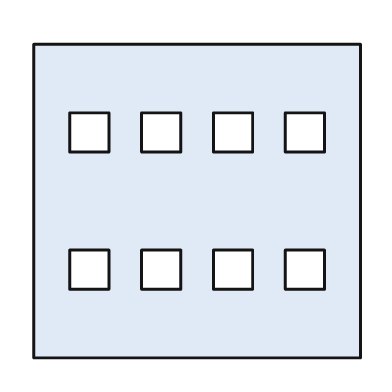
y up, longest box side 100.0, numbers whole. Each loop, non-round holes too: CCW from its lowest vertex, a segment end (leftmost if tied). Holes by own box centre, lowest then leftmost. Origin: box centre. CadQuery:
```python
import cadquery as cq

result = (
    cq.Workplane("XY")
    .moveTo(-50.0, -48.0)
    .lineTo(50.0, -48.0)
    .lineTo(50.0, 48.0)
    .lineTo(-50.0, 48.0)
    .close()
    .moveTo(-39.0, -27.0)
    .lineTo(-27.0, -27.0)
    .lineTo(-27.0, -15.0)
    .lineTo(-39.0, -15.0)
    .close()
    .moveTo(-17.0, -27.0)
    .lineTo(-5.0, -27.0)
    .lineTo(-5.0, -15.0)
    .lineTo(-17.0, -15.0)
    .close()
    .moveTo(5.0, -27.0)
    .lineTo(17.0, -27.0)
    .lineTo(17.0, -15.0)
    .lineTo(5.0, -15.0)
    .close()
    .moveTo(27.0, -27.0)
    .lineTo(39.0, -27.0)
    .lineTo(39.0, -15.0)
    .lineTo(27.0, -15.0)
    .close()
    .moveTo(-39.0, 15.0)
    .lineTo(-27.0, 15.0)
    .lineTo(-27.0, 27.0)
    .lineTo(-39.0, 27.0)
    .close()
    .moveTo(-17.0, 15.0)
    .lineTo(-5.0, 15.0)
    .lineTo(-5.0, 27.0)
    .lineTo(-17.0, 27.0)
    .close()
    .moveTo(5.0, 15.0)
    .lineTo(17.0, 15.0)
    .lineTo(17.0, 27.0)
    .lineTo(5.0, 27.0)
    .close()
    .moveTo(27.0, 15.0)
    .lineTo(39.0, 15.0)
    .lineTo(39.0, 27.0)
    .lineTo(27.0, 27.0)
    .close()
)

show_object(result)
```